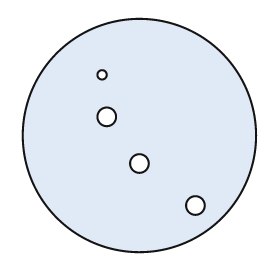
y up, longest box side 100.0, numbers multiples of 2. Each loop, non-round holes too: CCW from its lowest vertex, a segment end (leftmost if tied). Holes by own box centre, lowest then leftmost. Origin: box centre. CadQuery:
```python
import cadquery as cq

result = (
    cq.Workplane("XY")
    .moveTo(0.0, 0.0)
    .circle(50.0)
    .moveTo(24.0, -30.0)
    .circle(4.0)
    .moveTo(0.0, -12.0)
    .circle(4.0)
    .moveTo(-14.0, 8.0)
    .circle(4.0)
    .moveTo(-16.0, 26.0)
    .circle(2.0)
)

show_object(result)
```